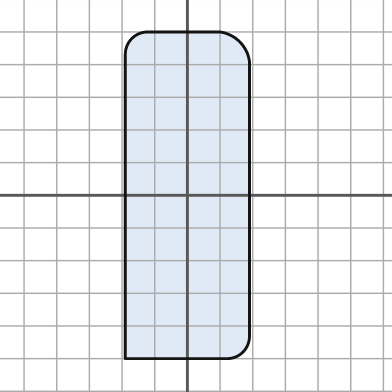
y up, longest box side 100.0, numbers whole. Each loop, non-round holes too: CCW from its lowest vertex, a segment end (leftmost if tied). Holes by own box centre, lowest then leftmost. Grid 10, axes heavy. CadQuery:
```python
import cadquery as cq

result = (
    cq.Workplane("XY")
    .moveTo(-19.0, -50.0)
    .lineTo(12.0, -50.0)
    .threePointArc((17.0, -48.0), (19.0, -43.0))
    .lineTo(19.0, 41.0)
    .threePointArc((16.0, 47.0), (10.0, 50.0))
    .lineTo(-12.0, 50.0)
    .threePointArc((-17.0, 48.0), (-19.0, 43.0))
    .close()
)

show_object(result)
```